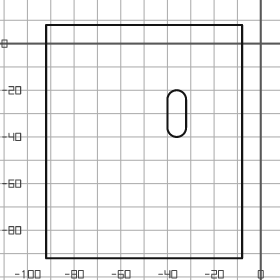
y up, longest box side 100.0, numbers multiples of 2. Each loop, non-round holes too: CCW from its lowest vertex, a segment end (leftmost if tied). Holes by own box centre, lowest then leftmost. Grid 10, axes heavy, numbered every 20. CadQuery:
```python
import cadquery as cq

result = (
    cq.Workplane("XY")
    .moveTo(-92.0, -92.0)
    .lineTo(-8.0, -92.0)
    .lineTo(-8.0, 8.0)
    .lineTo(-92.0, 8.0)
    .close()
    .moveTo(-40.0, -36.0)
    .threePointArc((-36.0, -40.0), (-32.0, -36.0))
    .lineTo(-32.0, -24.0)
    .threePointArc((-36.0, -20.0), (-40.0, -24.0))
    .close()
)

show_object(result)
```